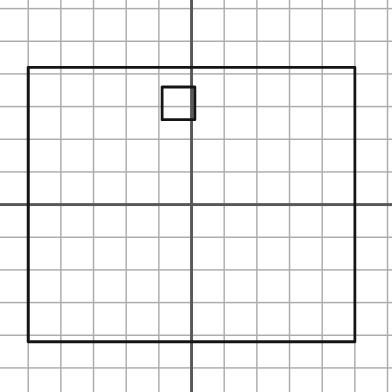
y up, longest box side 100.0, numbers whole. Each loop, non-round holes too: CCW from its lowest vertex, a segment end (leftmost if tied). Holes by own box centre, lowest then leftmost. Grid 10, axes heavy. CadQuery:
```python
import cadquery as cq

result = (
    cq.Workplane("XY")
    .moveTo(-50.0, -42.0)
    .lineTo(50.0, -42.0)
    .lineTo(50.0, 42.0)
    .lineTo(-50.0, 42.0)
    .close()
    .moveTo(-9.0, 26.0)
    .lineTo(1.0, 26.0)
    .lineTo(1.0, 36.0)
    .lineTo(-9.0, 36.0)
    .close()
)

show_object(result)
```